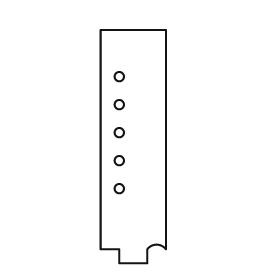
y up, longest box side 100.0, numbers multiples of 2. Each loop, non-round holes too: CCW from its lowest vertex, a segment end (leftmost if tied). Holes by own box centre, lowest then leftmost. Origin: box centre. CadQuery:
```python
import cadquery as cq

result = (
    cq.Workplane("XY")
    .moveTo(-6.0, -50.0)
    .lineTo(6.0, -50.0)
    .lineTo(6.0, -44.0)
    .threePointArc((10.0, -42.0), (14.0, -44.0))
    .lineTo(14.0, 50.0)
    .lineTo(-14.0, 50.0)
    .lineTo(-14.0, -44.0)
    .lineTo(-6.0, -44.0)
    .close()
    .moveTo(-6.0, -18.0)
    .circle(2.0)
    .moveTo(-6.0, -6.0)
    .circle(2.0)
    .moveTo(-6.0, 6.0)
    .circle(2.0)
    .moveTo(-6.0, 18.0)
    .circle(2.0)
    .moveTo(-6.0, 30.0)
    .circle(2.0)
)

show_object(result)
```